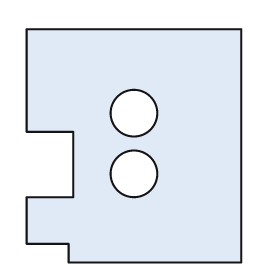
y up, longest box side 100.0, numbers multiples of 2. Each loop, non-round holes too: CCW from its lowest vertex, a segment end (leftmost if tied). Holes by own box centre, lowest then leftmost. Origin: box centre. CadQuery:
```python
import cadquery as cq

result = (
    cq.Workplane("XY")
    .moveTo(-28.0, -50.0)
    .lineTo(46.0, -50.0)
    .lineTo(46.0, 50.0)
    .lineTo(-46.0, 50.0)
    .lineTo(-46.0, 6.0)
    .lineTo(-26.0, 6.0)
    .lineTo(-26.0, -22.0)
    .lineTo(-46.0, -22.0)
    .lineTo(-46.0, -42.0)
    .lineTo(-28.0, -42.0)
    .close()
    .moveTo(0.0, -12.0)
    .circle(10.0)
    .moveTo(0.0, 14.0)
    .circle(10.0)
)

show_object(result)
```